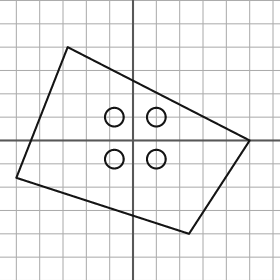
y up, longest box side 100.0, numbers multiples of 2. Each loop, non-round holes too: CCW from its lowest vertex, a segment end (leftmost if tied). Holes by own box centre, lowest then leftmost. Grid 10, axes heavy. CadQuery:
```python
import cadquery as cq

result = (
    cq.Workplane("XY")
    .moveTo(24.0, -40.0)
    .lineTo(50.0, 0.0)
    .lineTo(-28.0, 40.0)
    .lineTo(-50.0, -16.0)
    .close()
    .moveTo(-8.0, -8.0)
    .circle(4.0)
    .moveTo(10.0, -8.0)
    .circle(4.0)
    .moveTo(-8.0, 10.0)
    .circle(4.0)
    .moveTo(10.0, 10.0)
    .circle(4.0)
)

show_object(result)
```